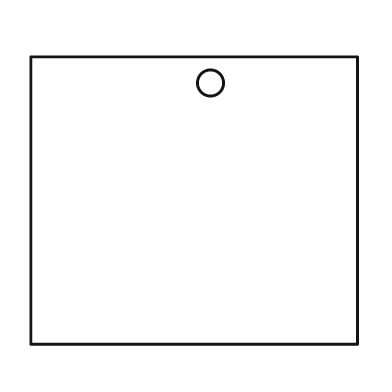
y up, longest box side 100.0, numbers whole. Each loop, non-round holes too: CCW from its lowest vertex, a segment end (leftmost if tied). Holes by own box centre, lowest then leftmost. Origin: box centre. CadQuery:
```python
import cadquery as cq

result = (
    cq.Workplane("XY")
    .moveTo(-50.0, -44.0)
    .lineTo(50.0, -44.0)
    .lineTo(50.0, 44.0)
    .lineTo(-50.0, 44.0)
    .close()
    .moveTo(5.0, 36.0)
    .circle(4.0)
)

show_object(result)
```